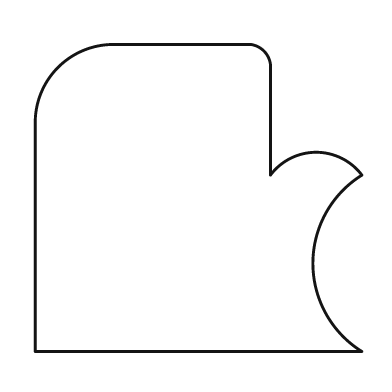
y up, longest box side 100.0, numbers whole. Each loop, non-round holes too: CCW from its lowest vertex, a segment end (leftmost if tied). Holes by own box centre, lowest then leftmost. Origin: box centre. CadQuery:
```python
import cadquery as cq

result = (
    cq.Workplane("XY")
    .moveTo(-50.0, -47.0)
    .lineTo(50.0, -47.0)
    .threePointArc((35.0, -20.0), (50.0, 7.0))
    .threePointArc((36.0, 14.0), (22.0, 7.0))
    .lineTo(22.0, 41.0)
    .threePointArc((20.0, 45.0), (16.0, 47.0))
    .lineTo(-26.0, 47.0)
    .threePointArc((-43.0, 40.0), (-50.0, 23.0))
    .close()
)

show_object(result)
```